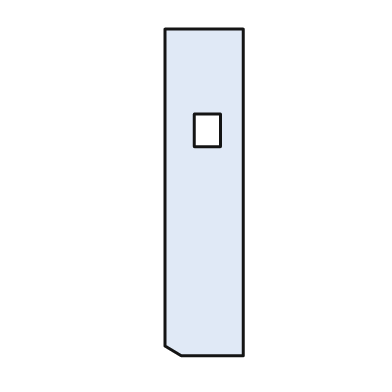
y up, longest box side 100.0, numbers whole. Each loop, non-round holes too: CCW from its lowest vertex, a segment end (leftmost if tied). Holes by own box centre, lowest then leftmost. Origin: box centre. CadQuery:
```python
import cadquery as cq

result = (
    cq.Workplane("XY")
    .moveTo(-7.0, -50.0)
    .lineTo(12.0, -50.0)
    .lineTo(12.0, 50.0)
    .lineTo(-12.0, 50.0)
    .lineTo(-12.0, -47.0)
    .close()
    .moveTo(-3.0, 14.0)
    .lineTo(5.0, 14.0)
    .lineTo(5.0, 24.0)
    .lineTo(-3.0, 24.0)
    .close()
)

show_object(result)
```